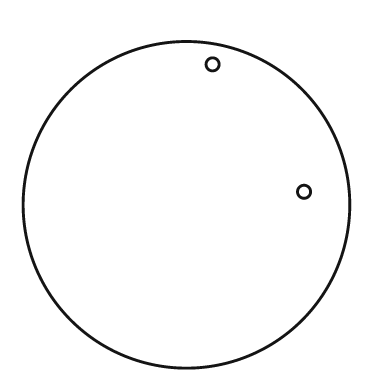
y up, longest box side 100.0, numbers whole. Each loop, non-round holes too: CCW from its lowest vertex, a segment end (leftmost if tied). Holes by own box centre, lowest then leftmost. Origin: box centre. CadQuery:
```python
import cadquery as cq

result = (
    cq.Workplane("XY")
    .moveTo(0.0, 0.0)
    .circle(50.0)
    .moveTo(36.0, 4.0)
    .circle(2.0)
    .moveTo(8.0, 43.0)
    .circle(2.0)
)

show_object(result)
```